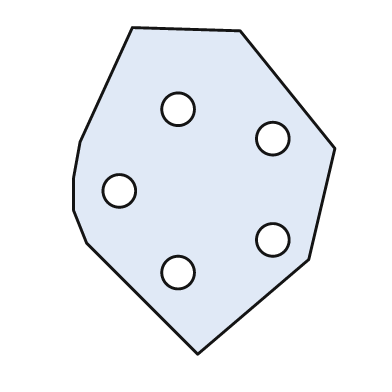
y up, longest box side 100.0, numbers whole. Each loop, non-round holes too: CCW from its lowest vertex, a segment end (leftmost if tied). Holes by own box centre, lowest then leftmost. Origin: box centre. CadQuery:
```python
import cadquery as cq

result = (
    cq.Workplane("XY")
    .moveTo(-2.0, -50.0)
    .lineTo(32.0, -21.0)
    .lineTo(40.0, 13.0)
    .lineTo(11.0, 49.0)
    .lineTo(-22.0, 50.0)
    .lineTo(-38.0, 15.0)
    .lineTo(-40.0, 4.0)
    .lineTo(-40.0, -6.0)
    .lineTo(-36.0, -16.0)
    .close()
    .moveTo(-8.0, -25.0)
    .circle(5.0)
    .moveTo(21.0, -15.0)
    .circle(5.0)
    .moveTo(-26.0, 0.0)
    .circle(5.0)
    .moveTo(21.0, 16.0)
    .circle(5.0)
    .moveTo(-8.0, 25.0)
    .circle(5.0)
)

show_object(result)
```